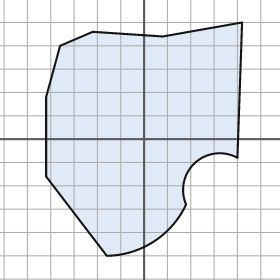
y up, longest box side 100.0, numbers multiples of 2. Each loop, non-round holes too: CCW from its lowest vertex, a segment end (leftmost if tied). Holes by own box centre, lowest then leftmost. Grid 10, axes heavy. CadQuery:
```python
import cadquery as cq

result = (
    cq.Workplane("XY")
    .moveTo(-16.0, -50.0)
    .threePointArc((4.0, -44.0), (18.0, -28.0))
    .threePointArc((22.0, -10.0), (40.0, -8.0))
    .lineTo(42.0, 50.0)
    .lineTo(8.0, 44.0)
    .lineTo(-22.0, 46.0)
    .lineTo(-36.0, 40.0)
    .lineTo(-42.0, 18.0)
    .lineTo(-42.0, -16.0)
    .close()
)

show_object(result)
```